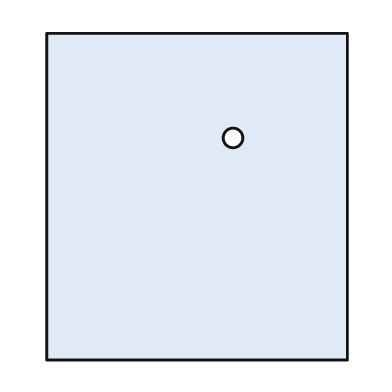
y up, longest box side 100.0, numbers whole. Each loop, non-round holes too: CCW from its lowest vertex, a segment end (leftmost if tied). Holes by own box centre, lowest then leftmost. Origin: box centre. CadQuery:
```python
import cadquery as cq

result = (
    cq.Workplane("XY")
    .moveTo(-46.0, -50.0)
    .lineTo(46.0, -50.0)
    .lineTo(46.0, 50.0)
    .lineTo(-46.0, 50.0)
    .close()
    .moveTo(11.0, 18.0)
    .circle(3.0)
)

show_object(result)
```